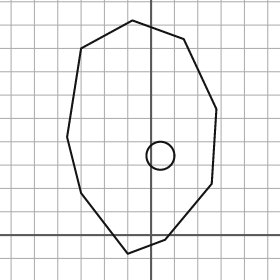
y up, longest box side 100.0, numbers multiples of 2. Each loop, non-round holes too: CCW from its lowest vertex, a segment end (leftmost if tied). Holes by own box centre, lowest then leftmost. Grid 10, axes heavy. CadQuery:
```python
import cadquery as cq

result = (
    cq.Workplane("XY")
    .moveTo(-10.0, -8.0)
    .lineTo(6.0, -2.0)
    .lineTo(26.0, 22.0)
    .lineTo(28.0, 54.0)
    .lineTo(14.0, 84.0)
    .lineTo(-8.0, 92.0)
    .lineTo(-30.0, 80.0)
    .lineTo(-36.0, 42.0)
    .lineTo(-30.0, 18.0)
    .close()
    .moveTo(4.0, 34.0)
    .circle(6.0)
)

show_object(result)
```